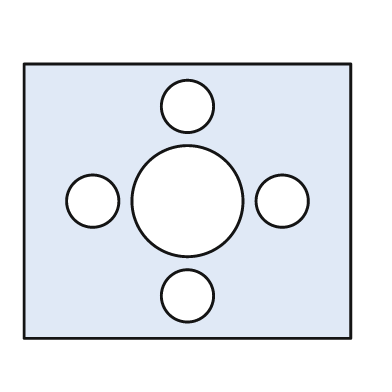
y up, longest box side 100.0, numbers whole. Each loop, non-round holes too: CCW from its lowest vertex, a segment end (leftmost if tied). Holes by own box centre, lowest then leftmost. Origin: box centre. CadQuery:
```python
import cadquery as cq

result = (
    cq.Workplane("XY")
    .moveTo(-50.0, -42.0)
    .lineTo(50.0, -42.0)
    .lineTo(50.0, 42.0)
    .lineTo(-50.0, 42.0)
    .close()
    .moveTo(0.0, -29.0)
    .circle(8.0)
    .moveTo(-29.0, 0.0)
    .circle(8.0)
    .moveTo(0.0, 0.0)
    .circle(17.0)
    .moveTo(29.0, 0.0)
    .circle(8.0)
    .moveTo(0.0, 29.0)
    .circle(8.0)
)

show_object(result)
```